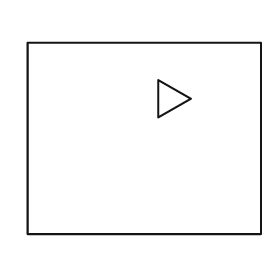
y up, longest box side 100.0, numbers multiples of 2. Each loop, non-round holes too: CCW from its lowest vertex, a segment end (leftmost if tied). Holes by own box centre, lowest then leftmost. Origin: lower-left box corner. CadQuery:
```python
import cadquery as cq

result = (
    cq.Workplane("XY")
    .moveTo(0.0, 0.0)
    .lineTo(100.0, 0.0)
    .lineTo(100.0, 82.0)
    .lineTo(0.0, 82.0)
    .close()
    .moveTo(56.0, 50.0)
    .lineTo(70.0, 58.0)
    .lineTo(56.0, 66.0)
    .close()
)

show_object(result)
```